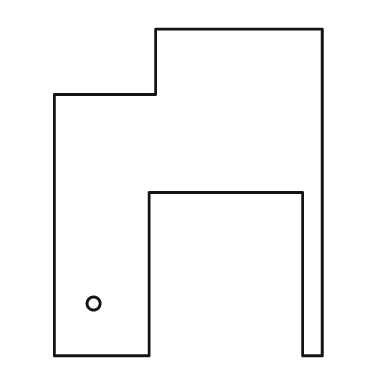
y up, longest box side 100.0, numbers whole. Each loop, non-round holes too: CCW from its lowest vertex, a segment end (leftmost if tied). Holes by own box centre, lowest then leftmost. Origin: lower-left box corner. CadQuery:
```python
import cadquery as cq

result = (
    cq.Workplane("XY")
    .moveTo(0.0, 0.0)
    .lineTo(29.0, 0.0)
    .lineTo(29.0, 50.0)
    .lineTo(76.0, 50.0)
    .lineTo(76.0, 0.0)
    .lineTo(82.0, 0.0)
    .lineTo(82.0, 100.0)
    .lineTo(31.0, 100.0)
    .lineTo(31.0, 80.0)
    .lineTo(0.0, 80.0)
    .close()
    .moveTo(12.0, 16.0)
    .circle(2.0)
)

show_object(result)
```